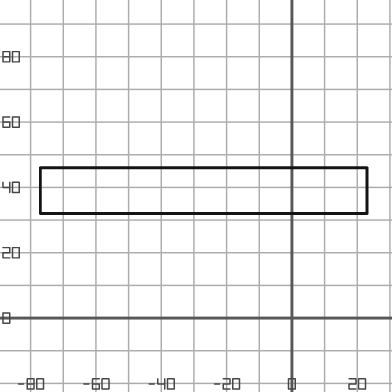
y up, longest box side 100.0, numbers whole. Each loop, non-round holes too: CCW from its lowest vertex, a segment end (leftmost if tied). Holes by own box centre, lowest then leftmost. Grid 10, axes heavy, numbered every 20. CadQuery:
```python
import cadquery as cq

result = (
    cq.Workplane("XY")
    .moveTo(-77.0, 32.0)
    .lineTo(23.0, 32.0)
    .lineTo(23.0, 46.0)
    .lineTo(-77.0, 46.0)
    .close()
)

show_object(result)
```